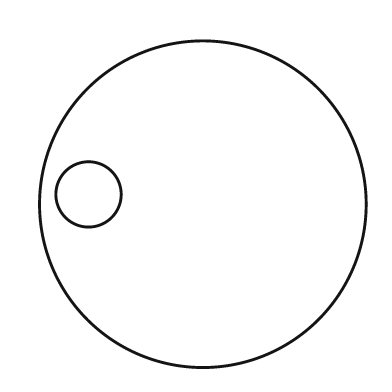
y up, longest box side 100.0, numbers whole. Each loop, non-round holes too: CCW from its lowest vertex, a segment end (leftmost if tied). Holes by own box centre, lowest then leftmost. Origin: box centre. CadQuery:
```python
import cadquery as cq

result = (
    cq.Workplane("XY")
    .moveTo(0.0, 0.0)
    .circle(50.0)
    .moveTo(-35.0, 3.0)
    .circle(10.0)
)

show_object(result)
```